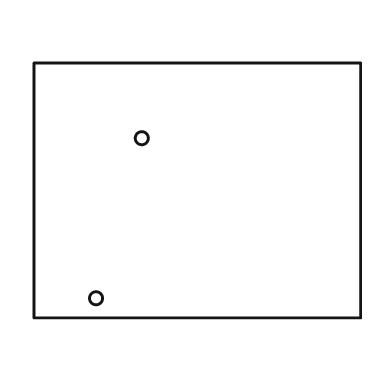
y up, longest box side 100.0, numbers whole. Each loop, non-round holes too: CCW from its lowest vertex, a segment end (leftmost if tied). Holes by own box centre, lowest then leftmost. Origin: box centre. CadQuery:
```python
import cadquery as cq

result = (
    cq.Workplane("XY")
    .moveTo(-50.0, -39.0)
    .lineTo(50.0, -39.0)
    .lineTo(50.0, 39.0)
    .lineTo(-50.0, 39.0)
    .close()
    .moveTo(-31.0, -33.0)
    .circle(2.0)
    .moveTo(-17.0, 16.0)
    .circle(2.0)
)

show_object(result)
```